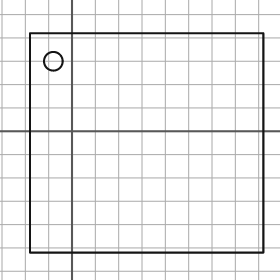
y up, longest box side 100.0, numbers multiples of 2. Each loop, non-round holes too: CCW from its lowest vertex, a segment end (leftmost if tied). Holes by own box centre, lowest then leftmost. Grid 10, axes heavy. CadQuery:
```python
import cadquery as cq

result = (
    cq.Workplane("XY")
    .moveTo(-18.0, -52.0)
    .lineTo(82.0, -52.0)
    .lineTo(82.0, 42.0)
    .lineTo(-18.0, 42.0)
    .close()
    .moveTo(-8.0, 30.0)
    .circle(4.0)
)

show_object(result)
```